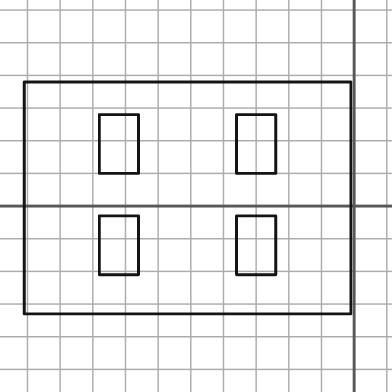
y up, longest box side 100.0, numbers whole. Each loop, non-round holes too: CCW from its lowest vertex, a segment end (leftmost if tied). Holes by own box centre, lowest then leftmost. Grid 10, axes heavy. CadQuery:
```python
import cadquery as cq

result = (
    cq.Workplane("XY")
    .moveTo(-101.0, -33.0)
    .lineTo(-1.0, -33.0)
    .lineTo(-1.0, 38.0)
    .lineTo(-101.0, 38.0)
    .close()
    .moveTo(-78.0, -21.0)
    .lineTo(-66.0, -21.0)
    .lineTo(-66.0, -3.0)
    .lineTo(-78.0, -3.0)
    .close()
    .moveTo(-36.0, -21.0)
    .lineTo(-24.0, -21.0)
    .lineTo(-24.0, -3.0)
    .lineTo(-36.0, -3.0)
    .close()
    .moveTo(-78.0, 10.0)
    .lineTo(-66.0, 10.0)
    .lineTo(-66.0, 28.0)
    .lineTo(-78.0, 28.0)
    .close()
    .moveTo(-36.0, 10.0)
    .lineTo(-24.0, 10.0)
    .lineTo(-24.0, 28.0)
    .lineTo(-36.0, 28.0)
    .close()
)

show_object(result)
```